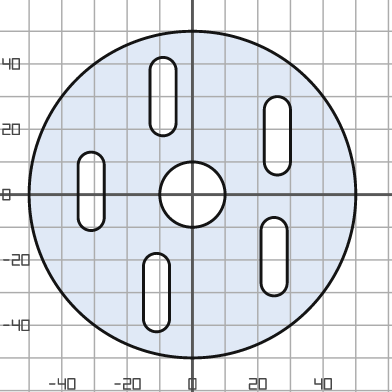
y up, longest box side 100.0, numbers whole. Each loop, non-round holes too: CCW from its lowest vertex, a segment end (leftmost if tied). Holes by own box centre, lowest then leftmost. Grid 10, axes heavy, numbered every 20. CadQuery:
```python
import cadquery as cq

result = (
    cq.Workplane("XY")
    .moveTo(0.0, 0.0)
    .circle(50.0)
    .moveTo(-15.0, -38.0)
    .threePointArc((-11.0, -42.0), (-7.0, -38.0))
    .lineTo(-7.0, -22.0)
    .threePointArc((-11.0, -18.0), (-15.0, -22.0))
    .close()
    .moveTo(21.0, -27.0)
    .threePointArc((25.0, -31.0), (29.0, -27.0))
    .lineTo(29.0, -11.0)
    .threePointArc((25.0, -7.0), (21.0, -11.0))
    .close()
    .moveTo(0.0, 0.0)
    .circle(10.0)
    .moveTo(-35.0, -7.0)
    .threePointArc((-31.0, -11.0), (-27.0, -7.0))
    .lineTo(-27.0, 9.0)
    .threePointArc((-31.0, 13.0), (-35.0, 9.0))
    .close()
    .moveTo(22.0, 10.0)
    .threePointArc((26.0, 6.0), (30.0, 10.0))
    .lineTo(30.0, 26.0)
    .threePointArc((26.0, 30.0), (22.0, 26.0))
    .close()
    .moveTo(-13.0, 22.0)
    .threePointArc((-9.0, 18.0), (-5.0, 22.0))
    .lineTo(-5.0, 38.0)
    .threePointArc((-9.0, 42.0), (-13.0, 38.0))
    .close()
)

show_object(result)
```